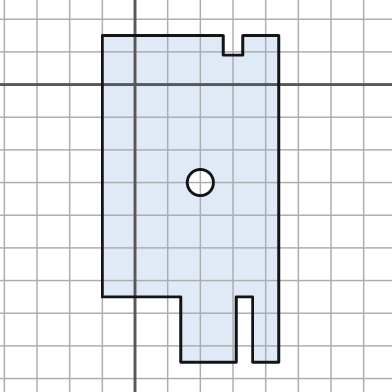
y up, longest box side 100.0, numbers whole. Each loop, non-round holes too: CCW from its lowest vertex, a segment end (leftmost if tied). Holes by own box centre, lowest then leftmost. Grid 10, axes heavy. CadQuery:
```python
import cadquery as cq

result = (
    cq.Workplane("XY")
    .moveTo(14.0, -85.0)
    .lineTo(31.0, -85.0)
    .lineTo(31.0, -65.0)
    .lineTo(36.0, -65.0)
    .lineTo(36.0, -85.0)
    .lineTo(44.0, -85.0)
    .lineTo(44.0, 15.0)
    .lineTo(33.0, 15.0)
    .lineTo(33.0, 9.0)
    .lineTo(27.0, 9.0)
    .lineTo(27.0, 15.0)
    .lineTo(-10.0, 15.0)
    .lineTo(-10.0, -65.0)
    .lineTo(14.0, -65.0)
    .close()
    .moveTo(20.0, -30.0)
    .circle(4.0)
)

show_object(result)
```